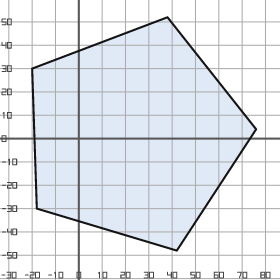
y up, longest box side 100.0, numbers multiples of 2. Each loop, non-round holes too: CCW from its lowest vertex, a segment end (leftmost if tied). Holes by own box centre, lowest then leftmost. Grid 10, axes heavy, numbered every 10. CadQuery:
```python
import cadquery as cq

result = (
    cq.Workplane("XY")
    .moveTo(42.0, -48.0)
    .lineTo(76.0, 4.0)
    .lineTo(38.0, 52.0)
    .lineTo(-20.0, 30.0)
    .lineTo(-18.0, -30.0)
    .close()
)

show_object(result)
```